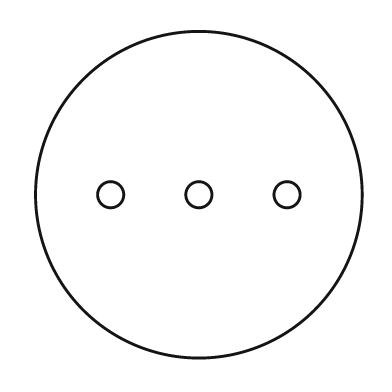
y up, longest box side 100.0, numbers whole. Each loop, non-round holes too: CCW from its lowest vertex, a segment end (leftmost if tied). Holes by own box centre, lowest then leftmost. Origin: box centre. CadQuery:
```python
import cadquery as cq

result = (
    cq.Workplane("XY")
    .moveTo(0.0, 0.0)
    .circle(50.0)
    .moveTo(-27.0, 0.0)
    .circle(4.0)
    .moveTo(0.0, 0.0)
    .circle(4.0)
    .moveTo(27.0, 0.0)
    .circle(4.0)
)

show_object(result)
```